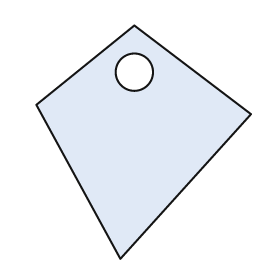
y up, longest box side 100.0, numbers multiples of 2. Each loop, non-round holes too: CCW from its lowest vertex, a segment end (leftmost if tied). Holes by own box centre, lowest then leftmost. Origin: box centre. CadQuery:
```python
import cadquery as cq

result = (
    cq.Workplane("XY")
    .moveTo(-10.0, -50.0)
    .lineTo(46.0, 12.0)
    .lineTo(-4.0, 50.0)
    .lineTo(-46.0, 16.0)
    .close()
    .moveTo(-4.0, 30.0)
    .circle(8.0)
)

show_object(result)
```